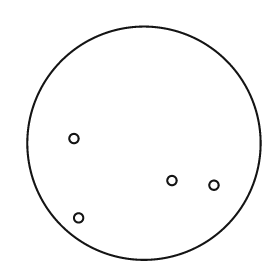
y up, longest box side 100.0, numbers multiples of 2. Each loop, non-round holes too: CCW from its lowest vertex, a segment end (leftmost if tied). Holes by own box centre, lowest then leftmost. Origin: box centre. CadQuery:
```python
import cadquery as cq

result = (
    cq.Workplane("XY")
    .moveTo(0.0, 0.0)
    .circle(50.0)
    .moveTo(-28.0, -32.0)
    .circle(2.0)
    .moveTo(30.0, -18.0)
    .circle(2.0)
    .moveTo(12.0, -16.0)
    .circle(2.0)
    .moveTo(-30.0, 2.0)
    .circle(2.0)
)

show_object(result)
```